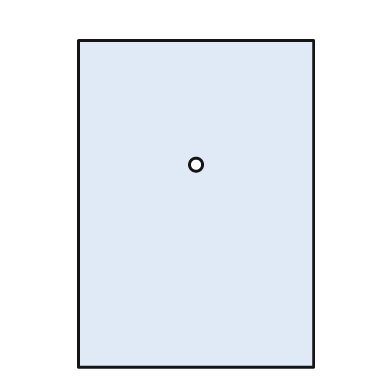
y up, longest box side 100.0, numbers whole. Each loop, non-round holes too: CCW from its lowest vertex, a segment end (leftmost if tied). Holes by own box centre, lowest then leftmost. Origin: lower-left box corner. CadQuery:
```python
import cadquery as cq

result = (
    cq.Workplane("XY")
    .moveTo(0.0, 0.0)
    .lineTo(72.0, 0.0)
    .lineTo(72.0, 100.0)
    .lineTo(0.0, 100.0)
    .close()
    .moveTo(36.0, 62.0)
    .circle(2.0)
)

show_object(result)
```